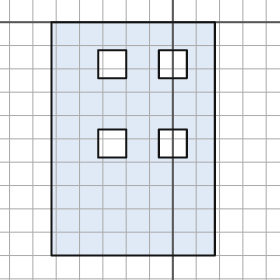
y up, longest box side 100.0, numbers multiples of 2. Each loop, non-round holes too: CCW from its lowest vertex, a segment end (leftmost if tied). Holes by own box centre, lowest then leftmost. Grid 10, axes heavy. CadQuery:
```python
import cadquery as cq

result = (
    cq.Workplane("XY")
    .moveTo(-52.0, -100.0)
    .lineTo(18.0, -100.0)
    .lineTo(18.0, 0.0)
    .lineTo(-52.0, 0.0)
    .close()
    .moveTo(-32.0, -58.0)
    .lineTo(-20.0, -58.0)
    .lineTo(-20.0, -46.0)
    .lineTo(-32.0, -46.0)
    .close()
    .moveTo(-6.0, -58.0)
    .lineTo(6.0, -58.0)
    .lineTo(6.0, -46.0)
    .lineTo(-6.0, -46.0)
    .close()
    .moveTo(-32.0, -24.0)
    .lineTo(-20.0, -24.0)
    .lineTo(-20.0, -12.0)
    .lineTo(-32.0, -12.0)
    .close()
    .moveTo(-6.0, -24.0)
    .lineTo(6.0, -24.0)
    .lineTo(6.0, -12.0)
    .lineTo(-6.0, -12.0)
    .close()
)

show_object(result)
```